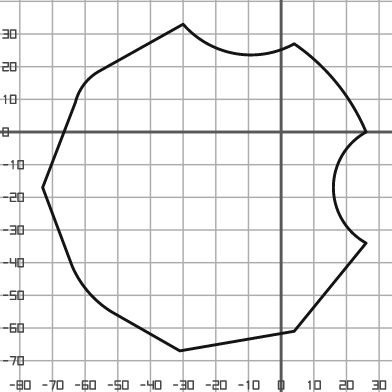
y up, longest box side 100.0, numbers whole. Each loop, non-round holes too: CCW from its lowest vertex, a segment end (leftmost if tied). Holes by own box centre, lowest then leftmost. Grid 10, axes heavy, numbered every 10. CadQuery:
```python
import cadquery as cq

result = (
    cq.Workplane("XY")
    .moveTo(-31.0, -67.0)
    .lineTo(4.0, -61.0)
    .lineTo(26.0, -34.0)
    .threePointArc((16.0, -17.0), (26.0, 0.0))
    .threePointArc((17.0, 15.0), (4.0, 27.0))
    .threePointArc((-14.0, 24.0), (-30.0, 33.0))
    .lineTo(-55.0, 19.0)
    .threePointArc((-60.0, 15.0), (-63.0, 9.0))
    .lineTo(-73.0, -17.0)
    .lineTo(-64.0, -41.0)
    .threePointArc((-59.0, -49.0), (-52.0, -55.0))
    .close()
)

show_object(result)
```